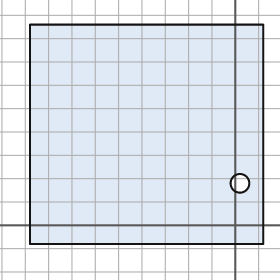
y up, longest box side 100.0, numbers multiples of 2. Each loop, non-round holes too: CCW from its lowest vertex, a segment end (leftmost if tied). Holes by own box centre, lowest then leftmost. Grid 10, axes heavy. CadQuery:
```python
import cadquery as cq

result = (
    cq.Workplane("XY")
    .moveTo(-88.0, -8.0)
    .lineTo(12.0, -8.0)
    .lineTo(12.0, 86.0)
    .lineTo(-88.0, 86.0)
    .close()
    .moveTo(2.0, 18.0)
    .circle(4.0)
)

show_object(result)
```